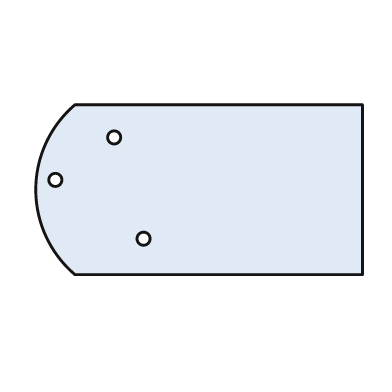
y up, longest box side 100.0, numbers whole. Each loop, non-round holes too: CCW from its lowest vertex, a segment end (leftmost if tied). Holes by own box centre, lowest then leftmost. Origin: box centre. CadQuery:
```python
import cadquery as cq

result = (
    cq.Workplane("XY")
    .moveTo(-38.0, -26.0)
    .lineTo(50.0, -26.0)
    .lineTo(50.0, 26.0)
    .lineTo(-38.0, 26.0)
    .threePointArc((-50.0, 0.0), (-38.0, -26.0))
    .close()
    .moveTo(-17.0, -15.0)
    .circle(2.0)
    .moveTo(-44.0, 3.0)
    .circle(2.0)
    .moveTo(-26.0, 16.0)
    .circle(2.0)
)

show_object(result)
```